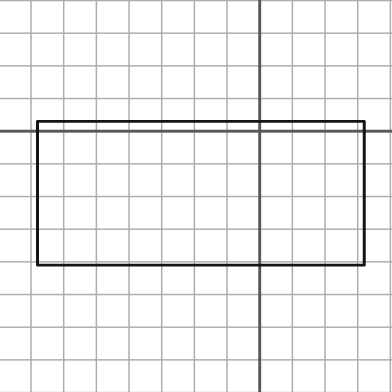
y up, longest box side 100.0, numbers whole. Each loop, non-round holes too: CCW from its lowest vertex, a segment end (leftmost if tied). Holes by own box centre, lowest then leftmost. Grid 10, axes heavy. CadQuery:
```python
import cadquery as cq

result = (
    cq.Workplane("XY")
    .moveTo(-68.0, -41.0)
    .lineTo(32.0, -41.0)
    .lineTo(32.0, 3.0)
    .lineTo(-68.0, 3.0)
    .close()
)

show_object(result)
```